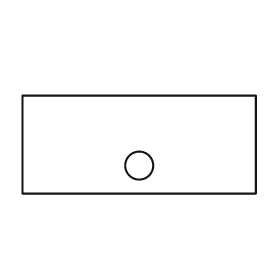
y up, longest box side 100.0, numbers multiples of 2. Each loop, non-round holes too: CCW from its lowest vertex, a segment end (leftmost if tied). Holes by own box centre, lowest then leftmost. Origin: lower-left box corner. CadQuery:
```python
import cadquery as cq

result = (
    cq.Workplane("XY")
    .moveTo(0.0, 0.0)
    .lineTo(100.0, 0.0)
    .lineTo(100.0, 42.0)
    .lineTo(0.0, 42.0)
    .close()
    .moveTo(50.0, 12.0)
    .circle(6.0)
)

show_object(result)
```